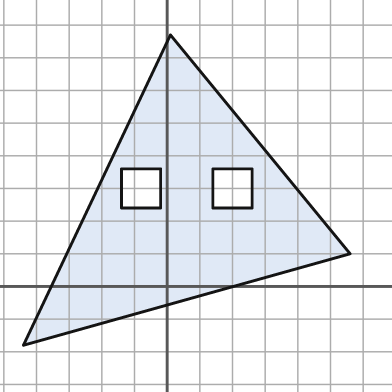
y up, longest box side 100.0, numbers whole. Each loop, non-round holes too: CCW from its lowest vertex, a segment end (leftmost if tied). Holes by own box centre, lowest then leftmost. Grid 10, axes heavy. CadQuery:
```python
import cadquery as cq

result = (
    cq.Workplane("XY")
    .moveTo(-44.0, -18.0)
    .lineTo(56.0, 10.0)
    .lineTo(1.0, 77.0)
    .close()
    .moveTo(-14.0, 24.0)
    .lineTo(-2.0, 24.0)
    .lineTo(-2.0, 36.0)
    .lineTo(-14.0, 36.0)
    .close()
    .moveTo(14.0, 24.0)
    .lineTo(26.0, 24.0)
    .lineTo(26.0, 36.0)
    .lineTo(14.0, 36.0)
    .close()
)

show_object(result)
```